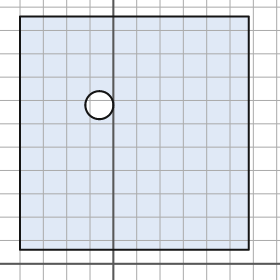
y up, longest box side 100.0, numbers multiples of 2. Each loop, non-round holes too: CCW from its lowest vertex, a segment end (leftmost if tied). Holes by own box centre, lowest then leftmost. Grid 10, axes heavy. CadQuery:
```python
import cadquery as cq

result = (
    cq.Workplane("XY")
    .moveTo(-40.0, 6.0)
    .lineTo(58.0, 6.0)
    .lineTo(58.0, 106.0)
    .lineTo(-40.0, 106.0)
    .close()
    .moveTo(-6.0, 68.0)
    .circle(6.0)
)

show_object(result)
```